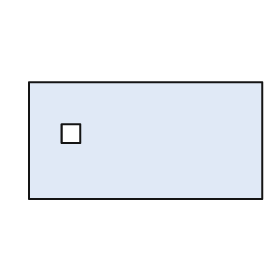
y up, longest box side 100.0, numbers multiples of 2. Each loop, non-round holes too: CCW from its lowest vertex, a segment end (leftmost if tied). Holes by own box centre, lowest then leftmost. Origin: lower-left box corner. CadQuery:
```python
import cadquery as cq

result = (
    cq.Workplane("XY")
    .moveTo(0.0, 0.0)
    .lineTo(100.0, 0.0)
    .lineTo(100.0, 50.0)
    .lineTo(0.0, 50.0)
    .close()
    .moveTo(14.0, 24.0)
    .lineTo(22.0, 24.0)
    .lineTo(22.0, 32.0)
    .lineTo(14.0, 32.0)
    .close()
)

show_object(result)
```